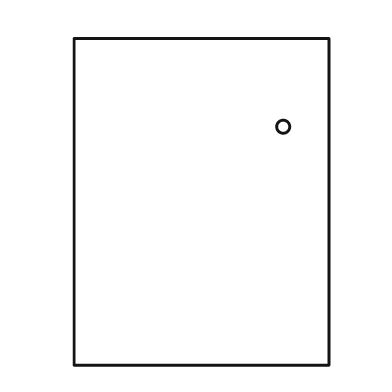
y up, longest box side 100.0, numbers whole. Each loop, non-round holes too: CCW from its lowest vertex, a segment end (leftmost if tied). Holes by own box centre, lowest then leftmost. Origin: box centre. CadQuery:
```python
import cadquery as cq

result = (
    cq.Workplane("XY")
    .moveTo(-39.0, -50.0)
    .lineTo(39.0, -50.0)
    .lineTo(39.0, 50.0)
    .lineTo(-39.0, 50.0)
    .close()
    .moveTo(25.0, 23.0)
    .circle(2.0)
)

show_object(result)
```